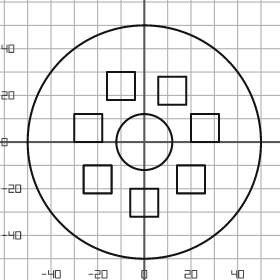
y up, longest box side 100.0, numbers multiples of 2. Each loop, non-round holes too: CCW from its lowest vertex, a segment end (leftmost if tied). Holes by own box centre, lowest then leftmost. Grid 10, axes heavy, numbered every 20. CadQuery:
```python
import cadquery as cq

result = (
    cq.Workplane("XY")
    .moveTo(0.0, 0.0)
    .circle(50.0)
    .moveTo(-6.0, -32.0)
    .lineTo(6.0, -32.0)
    .lineTo(6.0, -20.0)
    .lineTo(-6.0, -20.0)
    .close()
    .moveTo(-26.0, -22.0)
    .lineTo(-14.0, -22.0)
    .lineTo(-14.0, -10.0)
    .lineTo(-26.0, -10.0)
    .close()
    .moveTo(14.0, -22.0)
    .lineTo(26.0, -22.0)
    .lineTo(26.0, -10.0)
    .lineTo(14.0, -10.0)
    .close()
    .moveTo(0.0, 0.0)
    .circle(12.0)
    .moveTo(-30.0, 0.0)
    .lineTo(-18.0, 0.0)
    .lineTo(-18.0, 12.0)
    .lineTo(-30.0, 12.0)
    .close()
    .moveTo(20.0, 0.0)
    .lineTo(32.0, 0.0)
    .lineTo(32.0, 12.0)
    .lineTo(20.0, 12.0)
    .close()
    .moveTo(6.0, 16.0)
    .lineTo(18.0, 16.0)
    .lineTo(18.0, 28.0)
    .lineTo(6.0, 28.0)
    .close()
    .moveTo(-16.0, 18.0)
    .lineTo(-4.0, 18.0)
    .lineTo(-4.0, 30.0)
    .lineTo(-16.0, 30.0)
    .close()
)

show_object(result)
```